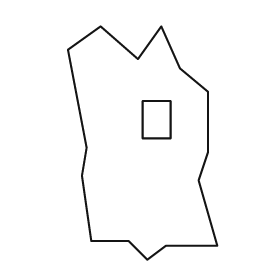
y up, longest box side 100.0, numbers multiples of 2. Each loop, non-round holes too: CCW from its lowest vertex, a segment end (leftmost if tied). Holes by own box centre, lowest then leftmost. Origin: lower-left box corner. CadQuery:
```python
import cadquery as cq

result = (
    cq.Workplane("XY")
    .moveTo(34.0, 0.0)
    .lineTo(42.0, 6.0)
    .lineTo(64.0, 6.0)
    .lineTo(56.0, 34.0)
    .lineTo(60.0, 46.0)
    .lineTo(60.0, 72.0)
    .lineTo(48.0, 82.0)
    .lineTo(40.0, 100.0)
    .lineTo(30.0, 86.0)
    .lineTo(14.0, 100.0)
    .lineTo(0.0, 90.0)
    .lineTo(8.0, 48.0)
    .lineTo(6.0, 36.0)
    .lineTo(10.0, 8.0)
    .lineTo(26.0, 8.0)
    .close()
    .moveTo(32.0, 52.0)
    .lineTo(44.0, 52.0)
    .lineTo(44.0, 68.0)
    .lineTo(32.0, 68.0)
    .close()
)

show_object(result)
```